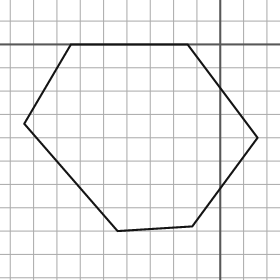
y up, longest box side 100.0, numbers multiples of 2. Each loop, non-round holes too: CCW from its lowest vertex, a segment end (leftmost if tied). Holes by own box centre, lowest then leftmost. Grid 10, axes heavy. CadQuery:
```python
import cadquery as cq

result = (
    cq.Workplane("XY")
    .moveTo(-44.0, -80.0)
    .lineTo(-12.0, -78.0)
    .lineTo(16.0, -40.0)
    .lineTo(-14.0, 0.0)
    .lineTo(-64.0, 0.0)
    .lineTo(-84.0, -34.0)
    .close()
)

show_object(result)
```